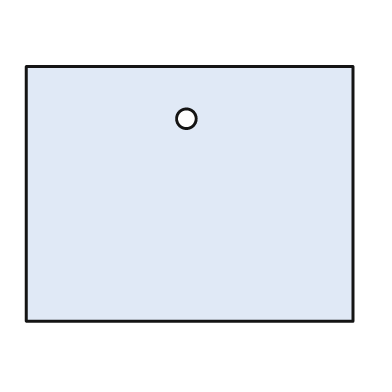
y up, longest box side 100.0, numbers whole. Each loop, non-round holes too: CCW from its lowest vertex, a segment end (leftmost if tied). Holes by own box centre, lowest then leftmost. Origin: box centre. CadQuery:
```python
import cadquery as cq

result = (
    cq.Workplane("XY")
    .moveTo(-50.0, -39.0)
    .lineTo(50.0, -39.0)
    .lineTo(50.0, 39.0)
    .lineTo(-50.0, 39.0)
    .close()
    .moveTo(-1.0, 23.0)
    .circle(3.0)
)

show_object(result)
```